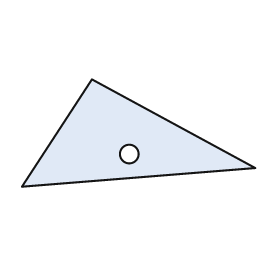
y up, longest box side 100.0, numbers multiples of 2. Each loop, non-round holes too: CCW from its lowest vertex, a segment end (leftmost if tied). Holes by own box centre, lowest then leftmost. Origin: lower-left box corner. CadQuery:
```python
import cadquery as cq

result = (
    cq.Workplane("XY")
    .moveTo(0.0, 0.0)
    .lineTo(100.0, 8.0)
    .lineTo(30.0, 46.0)
    .close()
    .moveTo(46.0, 14.0)
    .circle(4.0)
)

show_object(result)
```